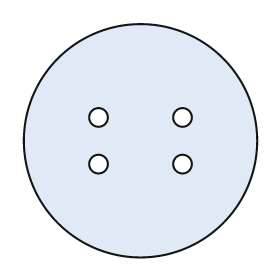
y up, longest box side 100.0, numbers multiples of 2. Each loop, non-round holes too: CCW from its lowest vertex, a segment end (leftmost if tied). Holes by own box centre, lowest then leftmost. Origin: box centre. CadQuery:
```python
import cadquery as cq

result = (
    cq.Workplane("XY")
    .moveTo(0.0, 0.0)
    .circle(50.0)
    .moveTo(-18.0, -10.0)
    .circle(4.0)
    .moveTo(18.0, -10.0)
    .circle(4.0)
    .moveTo(-18.0, 10.0)
    .circle(4.0)
    .moveTo(18.0, 10.0)
    .circle(4.0)
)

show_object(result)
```